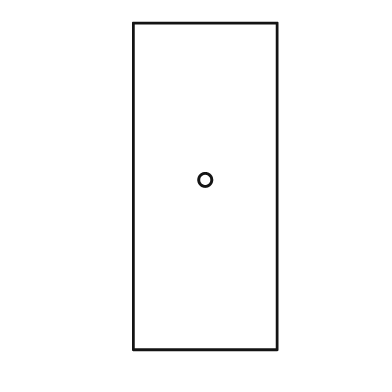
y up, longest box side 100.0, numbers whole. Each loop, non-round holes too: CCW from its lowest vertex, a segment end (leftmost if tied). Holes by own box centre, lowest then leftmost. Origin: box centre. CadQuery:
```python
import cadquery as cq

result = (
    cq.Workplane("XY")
    .moveTo(-22.0, -50.0)
    .lineTo(22.0, -50.0)
    .lineTo(22.0, 50.0)
    .lineTo(-22.0, 50.0)
    .close()
    .moveTo(0.0, 2.0)
    .circle(2.0)
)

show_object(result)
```